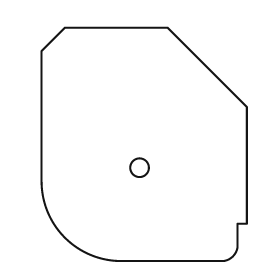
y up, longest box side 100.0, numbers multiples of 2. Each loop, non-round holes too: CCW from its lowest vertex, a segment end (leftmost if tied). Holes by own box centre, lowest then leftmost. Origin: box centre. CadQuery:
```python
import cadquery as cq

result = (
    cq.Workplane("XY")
    .moveTo(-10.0, -50.0)
    .lineTo(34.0, -50.0)
    .threePointArc((38.0, -48.0), (40.0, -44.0))
    .lineTo(40.0, -34.0)
    .lineTo(44.0, -34.0)
    .lineTo(44.0, 16.0)
    .lineTo(10.0, 50.0)
    .lineTo(-34.0, 50.0)
    .lineTo(-44.0, 40.0)
    .lineTo(-44.0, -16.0)
    .threePointArc((-34.0, -40.0), (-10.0, -50.0))
    .close()
    .moveTo(-2.0, -10.0)
    .circle(4.0)
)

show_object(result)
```